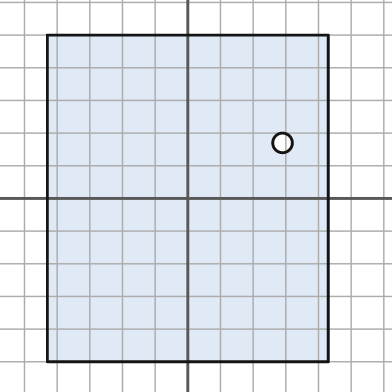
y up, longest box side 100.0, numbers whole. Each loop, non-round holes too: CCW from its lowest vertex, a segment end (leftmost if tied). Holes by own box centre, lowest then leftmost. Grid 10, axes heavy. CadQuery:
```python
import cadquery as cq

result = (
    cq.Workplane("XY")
    .moveTo(-43.0, -50.0)
    .lineTo(43.0, -50.0)
    .lineTo(43.0, 50.0)
    .lineTo(-43.0, 50.0)
    .close()
    .moveTo(29.0, 17.0)
    .circle(3.0)
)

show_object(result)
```